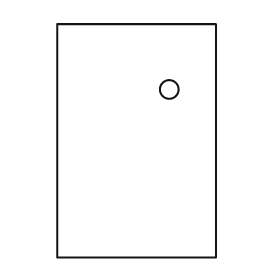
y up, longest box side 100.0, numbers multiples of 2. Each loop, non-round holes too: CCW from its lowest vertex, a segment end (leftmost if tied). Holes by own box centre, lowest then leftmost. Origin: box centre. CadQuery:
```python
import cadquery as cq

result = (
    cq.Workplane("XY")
    .moveTo(-34.0, -50.0)
    .lineTo(34.0, -50.0)
    .lineTo(34.0, 50.0)
    .lineTo(-34.0, 50.0)
    .close()
    .moveTo(14.0, 22.0)
    .circle(4.0)
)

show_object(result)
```